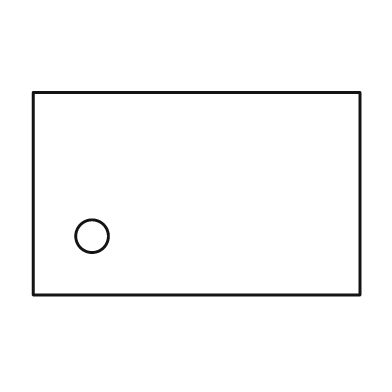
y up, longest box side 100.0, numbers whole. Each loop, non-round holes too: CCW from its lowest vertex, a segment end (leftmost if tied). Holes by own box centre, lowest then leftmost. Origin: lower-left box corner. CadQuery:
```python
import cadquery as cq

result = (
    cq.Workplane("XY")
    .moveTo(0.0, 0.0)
    .lineTo(100.0, 0.0)
    .lineTo(100.0, 62.0)
    .lineTo(0.0, 62.0)
    .close()
    .moveTo(18.0, 18.0)
    .circle(5.0)
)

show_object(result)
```